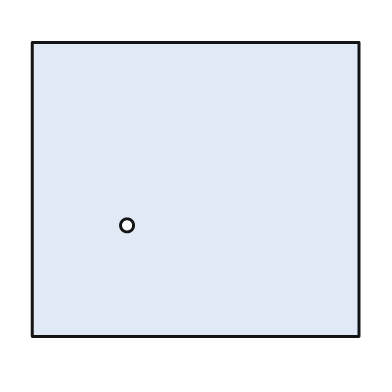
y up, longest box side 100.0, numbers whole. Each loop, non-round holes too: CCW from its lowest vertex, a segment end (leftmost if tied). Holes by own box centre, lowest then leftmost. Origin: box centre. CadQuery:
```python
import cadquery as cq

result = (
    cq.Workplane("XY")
    .moveTo(-50.0, -45.0)
    .lineTo(50.0, -45.0)
    .lineTo(50.0, 45.0)
    .lineTo(-50.0, 45.0)
    .close()
    .moveTo(-21.0, -11.0)
    .circle(2.0)
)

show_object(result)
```